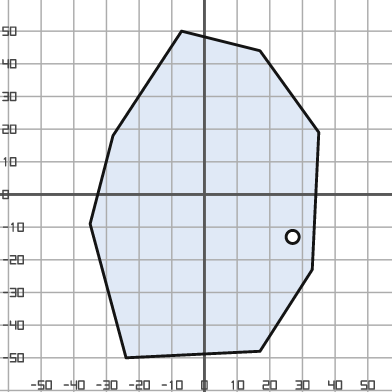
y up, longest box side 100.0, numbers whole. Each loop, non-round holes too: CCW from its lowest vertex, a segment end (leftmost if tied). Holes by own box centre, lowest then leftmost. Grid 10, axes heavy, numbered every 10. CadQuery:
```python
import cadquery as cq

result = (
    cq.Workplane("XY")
    .moveTo(-24.0, -50.0)
    .lineTo(17.0, -48.0)
    .lineTo(33.0, -23.0)
    .lineTo(35.0, 19.0)
    .lineTo(17.0, 44.0)
    .lineTo(-7.0, 50.0)
    .lineTo(-28.0, 18.0)
    .lineTo(-35.0, -9.0)
    .close()
    .moveTo(27.0, -13.0)
    .circle(2.0)
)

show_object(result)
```